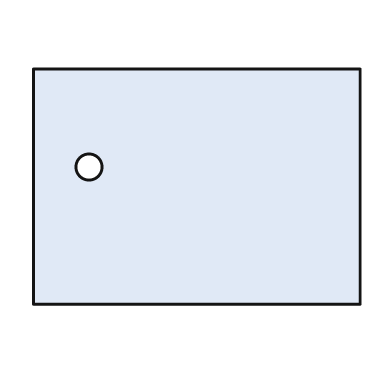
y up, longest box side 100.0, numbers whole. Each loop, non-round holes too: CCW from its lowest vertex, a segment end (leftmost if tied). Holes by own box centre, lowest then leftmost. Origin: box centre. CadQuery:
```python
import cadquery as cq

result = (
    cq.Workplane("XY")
    .moveTo(-50.0, -36.0)
    .lineTo(50.0, -36.0)
    .lineTo(50.0, 36.0)
    .lineTo(-50.0, 36.0)
    .close()
    .moveTo(-33.0, 6.0)
    .circle(4.0)
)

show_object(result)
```